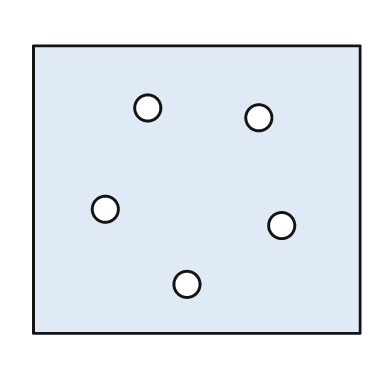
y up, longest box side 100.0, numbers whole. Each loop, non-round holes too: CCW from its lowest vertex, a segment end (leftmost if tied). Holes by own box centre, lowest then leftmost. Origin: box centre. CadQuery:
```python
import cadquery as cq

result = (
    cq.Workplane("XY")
    .moveTo(-50.0, -44.0)
    .lineTo(50.0, -44.0)
    .lineTo(50.0, 44.0)
    .lineTo(-50.0, 44.0)
    .close()
    .moveTo(-3.0, -29.0)
    .circle(4.0)
    .moveTo(26.0, -11.0)
    .circle(4.0)
    .moveTo(-28.0, -6.0)
    .circle(4.0)
    .moveTo(19.0, 22.0)
    .circle(4.0)
    .moveTo(-15.0, 25.0)
    .circle(4.0)
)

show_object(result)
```